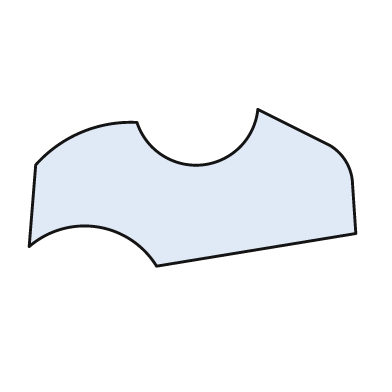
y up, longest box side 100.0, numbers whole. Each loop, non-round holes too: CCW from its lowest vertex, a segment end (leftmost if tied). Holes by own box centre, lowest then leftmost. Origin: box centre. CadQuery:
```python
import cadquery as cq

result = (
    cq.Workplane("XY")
    .moveTo(-11.0, -24.0)
    .lineTo(50.0, -14.0)
    .lineTo(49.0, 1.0)
    .threePointArc((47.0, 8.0), (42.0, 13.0))
    .lineTo(20.0, 24.0)
    .threePointArc((3.0, 7.0), (-17.0, 20.0))
    .threePointArc((-34.0, 17.0), (-48.0, 7.0))
    .lineTo(-50.0, -18.0)
    .threePointArc((-29.0, -12.0), (-11.0, -24.0))
    .close()
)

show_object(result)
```